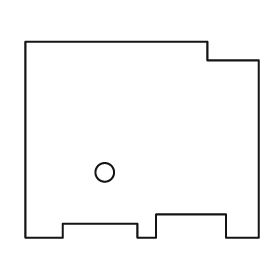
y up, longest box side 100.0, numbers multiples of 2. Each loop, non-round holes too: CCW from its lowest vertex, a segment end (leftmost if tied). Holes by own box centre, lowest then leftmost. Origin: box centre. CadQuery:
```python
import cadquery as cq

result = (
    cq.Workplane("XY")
    .moveTo(-50.0, -42.0)
    .lineTo(-34.0, -42.0)
    .lineTo(-34.0, -36.0)
    .lineTo(-2.0, -36.0)
    .lineTo(-2.0, -42.0)
    .lineTo(6.0, -42.0)
    .lineTo(6.0, -32.0)
    .lineTo(36.0, -32.0)
    .lineTo(36.0, -42.0)
    .lineTo(50.0, -42.0)
    .lineTo(50.0, 34.0)
    .lineTo(28.0, 34.0)
    .lineTo(28.0, 42.0)
    .lineTo(-50.0, 42.0)
    .close()
    .moveTo(-16.0, -14.0)
    .circle(4.0)
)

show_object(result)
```